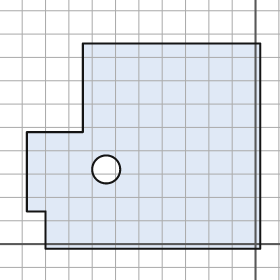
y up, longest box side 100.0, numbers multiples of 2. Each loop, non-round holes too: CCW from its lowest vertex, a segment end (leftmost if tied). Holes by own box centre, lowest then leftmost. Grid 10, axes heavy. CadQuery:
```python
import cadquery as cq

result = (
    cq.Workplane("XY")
    .moveTo(-90.0, -2.0)
    .lineTo(2.0, -2.0)
    .lineTo(2.0, 86.0)
    .lineTo(-74.0, 86.0)
    .lineTo(-74.0, 48.0)
    .lineTo(-98.0, 48.0)
    .lineTo(-98.0, 14.0)
    .lineTo(-90.0, 14.0)
    .close()
    .moveTo(-64.0, 32.0)
    .circle(6.0)
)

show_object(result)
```